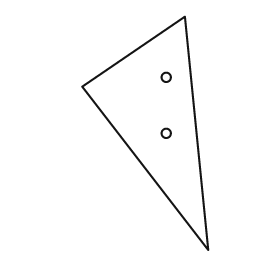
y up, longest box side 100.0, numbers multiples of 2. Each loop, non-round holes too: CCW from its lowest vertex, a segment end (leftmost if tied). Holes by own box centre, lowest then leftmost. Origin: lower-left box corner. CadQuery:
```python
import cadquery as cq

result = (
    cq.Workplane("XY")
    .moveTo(54.0, 0.0)
    .lineTo(44.0, 100.0)
    .lineTo(0.0, 70.0)
    .close()
    .moveTo(36.0, 50.0)
    .circle(2.0)
    .moveTo(36.0, 74.0)
    .circle(2.0)
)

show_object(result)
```